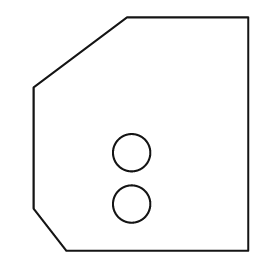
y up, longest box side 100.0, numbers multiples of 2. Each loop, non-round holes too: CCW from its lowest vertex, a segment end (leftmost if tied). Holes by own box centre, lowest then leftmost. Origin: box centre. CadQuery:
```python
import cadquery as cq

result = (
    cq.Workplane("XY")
    .moveTo(-32.0, -50.0)
    .lineTo(46.0, -50.0)
    .lineTo(46.0, 50.0)
    .lineTo(-6.0, 50.0)
    .lineTo(-46.0, 20.0)
    .lineTo(-46.0, -32.0)
    .close()
    .moveTo(-4.0, -30.0)
    .circle(8.0)
    .moveTo(-4.0, -8.0)
    .circle(8.0)
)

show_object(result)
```